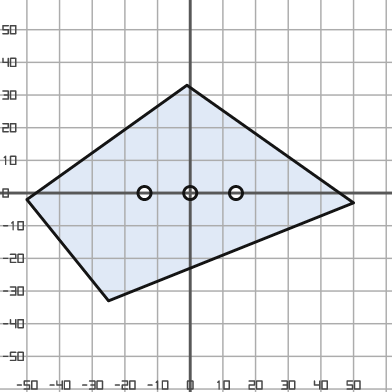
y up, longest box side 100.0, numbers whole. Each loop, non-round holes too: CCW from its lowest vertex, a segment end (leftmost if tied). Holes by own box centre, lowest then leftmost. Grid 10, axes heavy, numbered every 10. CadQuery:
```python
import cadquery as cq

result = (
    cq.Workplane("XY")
    .moveTo(-25.0, -33.0)
    .lineTo(50.0, -3.0)
    .lineTo(-1.0, 33.0)
    .lineTo(-50.0, -2.0)
    .close()
    .moveTo(-14.0, 0.0)
    .circle(2.0)
    .moveTo(0.0, 0.0)
    .circle(2.0)
    .moveTo(14.0, 0.0)
    .circle(2.0)
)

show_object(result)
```